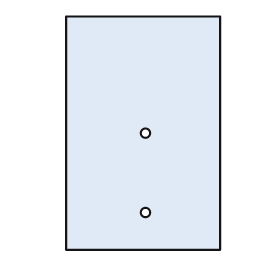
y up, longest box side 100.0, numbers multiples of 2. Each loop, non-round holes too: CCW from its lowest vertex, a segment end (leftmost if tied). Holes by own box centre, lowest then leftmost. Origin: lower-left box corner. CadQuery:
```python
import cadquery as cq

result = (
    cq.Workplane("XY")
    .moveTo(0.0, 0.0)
    .lineTo(66.0, 0.0)
    .lineTo(66.0, 100.0)
    .lineTo(0.0, 100.0)
    .close()
    .moveTo(34.0, 16.0)
    .circle(2.0)
    .moveTo(34.0, 50.0)
    .circle(2.0)
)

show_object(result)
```